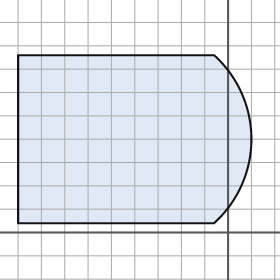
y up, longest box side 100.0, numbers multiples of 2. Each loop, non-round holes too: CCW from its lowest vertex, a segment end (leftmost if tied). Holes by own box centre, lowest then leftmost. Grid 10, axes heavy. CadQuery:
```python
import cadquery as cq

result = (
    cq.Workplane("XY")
    .moveTo(-90.0, 4.0)
    .lineTo(-6.0, 4.0)
    .threePointArc((10.0, 40.0), (-6.0, 76.0))
    .lineTo(-90.0, 76.0)
    .close()
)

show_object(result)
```